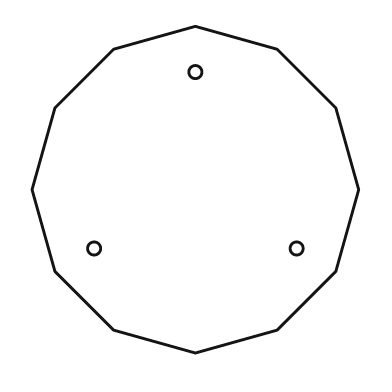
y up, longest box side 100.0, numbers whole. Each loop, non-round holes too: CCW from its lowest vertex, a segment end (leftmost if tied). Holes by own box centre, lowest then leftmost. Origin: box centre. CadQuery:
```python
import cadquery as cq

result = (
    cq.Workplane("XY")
    .moveTo(0.0, -50.0)
    .lineTo(25.0, -43.0)
    .lineTo(43.0, -25.0)
    .lineTo(50.0, 0.0)
    .lineTo(43.0, 25.0)
    .lineTo(25.0, 43.0)
    .lineTo(0.0, 50.0)
    .lineTo(-25.0, 43.0)
    .lineTo(-43.0, 25.0)
    .lineTo(-50.0, 0.0)
    .lineTo(-43.0, -25.0)
    .lineTo(-25.0, -43.0)
    .close()
    .moveTo(-31.0, -18.0)
    .circle(2.0)
    .moveTo(31.0, -18.0)
    .circle(2.0)
    .moveTo(0.0, 36.0)
    .circle(2.0)
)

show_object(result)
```